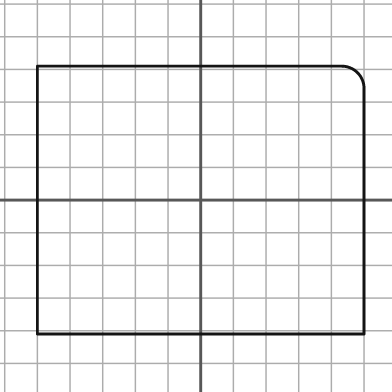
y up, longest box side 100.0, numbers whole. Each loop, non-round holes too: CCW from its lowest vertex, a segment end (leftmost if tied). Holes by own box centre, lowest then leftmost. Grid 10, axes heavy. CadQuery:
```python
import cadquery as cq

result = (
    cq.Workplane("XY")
    .moveTo(-50.0, -41.0)
    .lineTo(50.0, -41.0)
    .lineTo(50.0, 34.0)
    .threePointArc((48.0, 39.0), (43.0, 41.0))
    .lineTo(-50.0, 41.0)
    .close()
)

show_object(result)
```